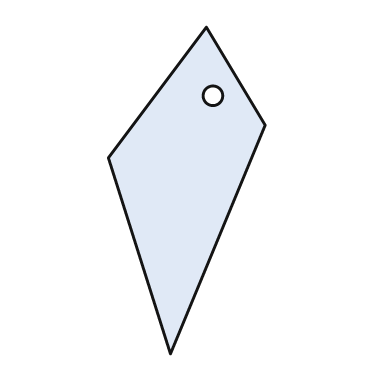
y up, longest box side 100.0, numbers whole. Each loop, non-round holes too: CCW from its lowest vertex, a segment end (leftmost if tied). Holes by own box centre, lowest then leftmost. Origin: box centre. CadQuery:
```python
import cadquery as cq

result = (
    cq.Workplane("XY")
    .moveTo(-5.0, -50.0)
    .lineTo(24.0, 20.0)
    .lineTo(6.0, 50.0)
    .lineTo(-24.0, 10.0)
    .close()
    .moveTo(8.0, 29.0)
    .circle(3.0)
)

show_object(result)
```